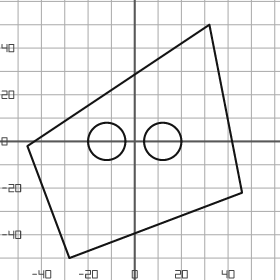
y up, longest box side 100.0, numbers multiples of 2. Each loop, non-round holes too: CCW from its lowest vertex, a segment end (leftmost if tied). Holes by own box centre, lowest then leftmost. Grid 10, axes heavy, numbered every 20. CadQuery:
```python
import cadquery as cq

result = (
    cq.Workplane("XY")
    .moveTo(-28.0, -50.0)
    .lineTo(46.0, -22.0)
    .lineTo(32.0, 50.0)
    .lineTo(-46.0, -2.0)
    .close()
    .moveTo(-12.0, 0.0)
    .circle(8.0)
    .moveTo(12.0, 0.0)
    .circle(8.0)
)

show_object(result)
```